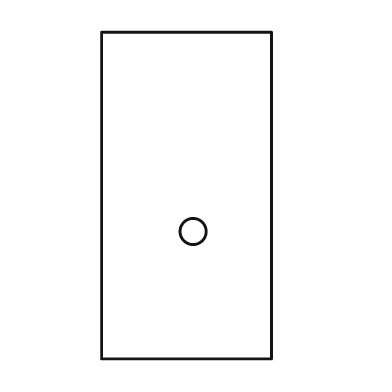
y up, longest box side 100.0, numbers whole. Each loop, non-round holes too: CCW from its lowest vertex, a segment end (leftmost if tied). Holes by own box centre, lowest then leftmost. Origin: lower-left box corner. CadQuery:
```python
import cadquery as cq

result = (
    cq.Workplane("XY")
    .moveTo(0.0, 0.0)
    .lineTo(52.0, 0.0)
    .lineTo(52.0, 100.0)
    .lineTo(0.0, 100.0)
    .close()
    .moveTo(28.0, 39.0)
    .circle(4.0)
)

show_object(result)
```